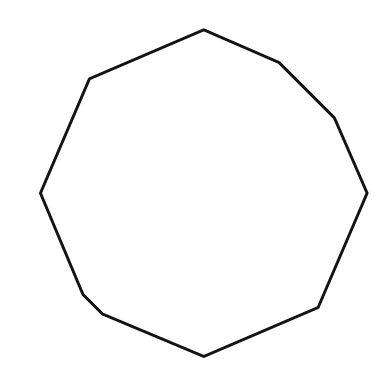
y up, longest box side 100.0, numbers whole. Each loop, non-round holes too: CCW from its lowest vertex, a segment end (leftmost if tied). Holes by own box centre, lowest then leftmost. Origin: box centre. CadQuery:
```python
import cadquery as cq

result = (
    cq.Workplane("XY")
    .moveTo(0.0, -50.0)
    .lineTo(35.0, -35.0)
    .lineTo(50.0, 0.0)
    .lineTo(40.0, 23.0)
    .lineTo(23.0, 40.0)
    .lineTo(0.0, 50.0)
    .lineTo(-35.0, 35.0)
    .lineTo(-50.0, 0.0)
    .lineTo(-37.0, -31.0)
    .lineTo(-31.0, -37.0)
    .close()
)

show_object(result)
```